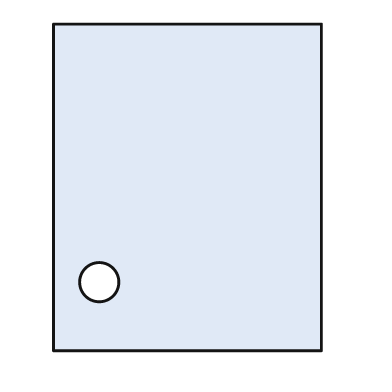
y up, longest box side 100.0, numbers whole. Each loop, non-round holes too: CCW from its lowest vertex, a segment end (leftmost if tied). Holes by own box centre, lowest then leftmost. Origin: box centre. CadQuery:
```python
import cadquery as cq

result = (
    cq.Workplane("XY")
    .moveTo(-41.0, -50.0)
    .lineTo(41.0, -50.0)
    .lineTo(41.0, 50.0)
    .lineTo(-41.0, 50.0)
    .close()
    .moveTo(-27.0, -29.0)
    .circle(6.0)
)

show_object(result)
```